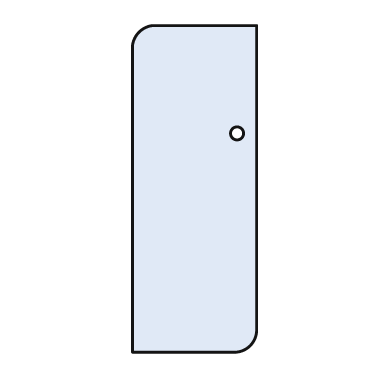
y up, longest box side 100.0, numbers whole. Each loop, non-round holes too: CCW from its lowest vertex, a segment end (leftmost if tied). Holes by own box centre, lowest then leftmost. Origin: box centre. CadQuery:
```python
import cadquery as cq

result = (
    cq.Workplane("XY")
    .moveTo(-19.0, -50.0)
    .lineTo(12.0, -50.0)
    .threePointArc((17.0, -48.0), (19.0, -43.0))
    .lineTo(19.0, 50.0)
    .lineTo(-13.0, 50.0)
    .threePointArc((-17.0, 48.0), (-19.0, 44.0))
    .close()
    .moveTo(13.0, 17.0)
    .circle(2.0)
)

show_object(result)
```